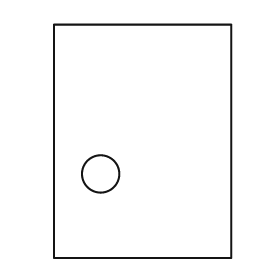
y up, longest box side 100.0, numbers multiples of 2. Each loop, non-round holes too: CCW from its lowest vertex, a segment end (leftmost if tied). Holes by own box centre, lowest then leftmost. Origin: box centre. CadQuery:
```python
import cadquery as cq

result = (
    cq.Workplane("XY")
    .moveTo(-38.0, -50.0)
    .lineTo(38.0, -50.0)
    .lineTo(38.0, 50.0)
    .lineTo(-38.0, 50.0)
    .close()
    .moveTo(-18.0, -14.0)
    .circle(8.0)
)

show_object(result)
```